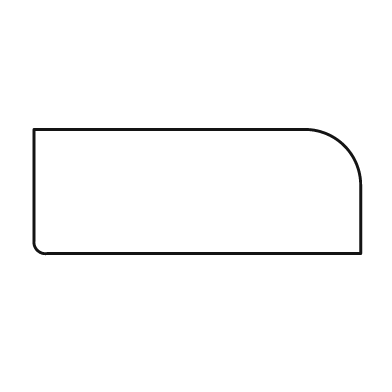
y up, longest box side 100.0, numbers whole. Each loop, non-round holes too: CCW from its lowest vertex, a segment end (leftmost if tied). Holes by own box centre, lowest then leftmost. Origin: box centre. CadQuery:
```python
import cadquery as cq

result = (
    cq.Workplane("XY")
    .moveTo(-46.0, -19.0)
    .lineTo(50.0, -19.0)
    .lineTo(50.0, 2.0)
    .threePointArc((45.0, 14.0), (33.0, 19.0))
    .lineTo(-50.0, 19.0)
    .lineTo(-50.0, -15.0)
    .threePointArc((-49.0, -18.0), (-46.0, -19.0))
    .close()
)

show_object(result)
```